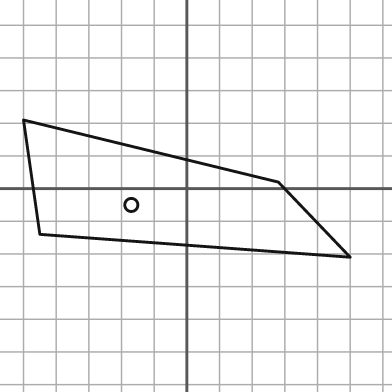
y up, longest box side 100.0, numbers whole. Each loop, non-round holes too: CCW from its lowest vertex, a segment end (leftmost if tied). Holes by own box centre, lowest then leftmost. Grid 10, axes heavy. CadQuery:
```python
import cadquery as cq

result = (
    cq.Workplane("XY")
    .moveTo(50.0, -21.0)
    .lineTo(28.0, 2.0)
    .lineTo(-50.0, 21.0)
    .lineTo(-45.0, -14.0)
    .close()
    .moveTo(-17.0, -5.0)
    .circle(2.0)
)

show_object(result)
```